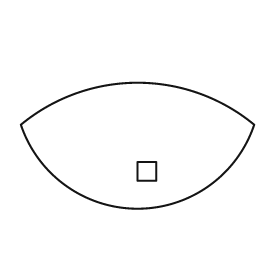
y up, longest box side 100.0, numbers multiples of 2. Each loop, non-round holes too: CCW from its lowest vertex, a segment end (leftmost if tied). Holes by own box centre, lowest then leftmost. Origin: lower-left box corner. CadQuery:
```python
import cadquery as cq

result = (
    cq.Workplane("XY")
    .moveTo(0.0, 36.0)
    .threePointArc((50.0, 0.0), (100.0, 36.0))
    .threePointArc((50.0, 54.0), (0.0, 36.0))
    .close()
    .moveTo(50.0, 12.0)
    .lineTo(58.0, 12.0)
    .lineTo(58.0, 20.0)
    .lineTo(50.0, 20.0)
    .close()
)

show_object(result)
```